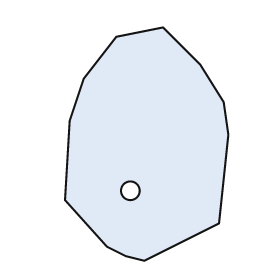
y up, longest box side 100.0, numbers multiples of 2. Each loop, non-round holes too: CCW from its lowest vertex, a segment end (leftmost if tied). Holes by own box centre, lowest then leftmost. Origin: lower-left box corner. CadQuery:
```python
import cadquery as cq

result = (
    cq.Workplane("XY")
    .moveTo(34.0, 0.0)
    .lineTo(66.0, 16.0)
    .lineTo(70.0, 54.0)
    .lineTo(68.0, 68.0)
    .lineTo(58.0, 84.0)
    .lineTo(42.0, 100.0)
    .lineTo(22.0, 96.0)
    .lineTo(8.0, 78.0)
    .lineTo(2.0, 60.0)
    .lineTo(0.0, 26.0)
    .lineTo(18.0, 6.0)
    .lineTo(26.0, 2.0)
    .close()
    .moveTo(28.0, 30.0)
    .circle(4.0)
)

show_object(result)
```